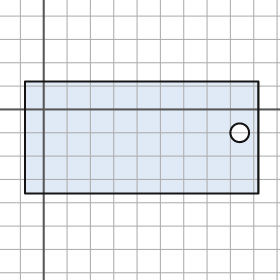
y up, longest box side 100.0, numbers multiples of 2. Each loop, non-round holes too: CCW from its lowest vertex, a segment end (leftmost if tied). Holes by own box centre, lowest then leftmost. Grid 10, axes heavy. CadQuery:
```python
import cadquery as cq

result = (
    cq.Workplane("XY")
    .moveTo(-8.0, -36.0)
    .lineTo(92.0, -36.0)
    .lineTo(92.0, 12.0)
    .lineTo(-8.0, 12.0)
    .close()
    .moveTo(84.0, -10.0)
    .circle(4.0)
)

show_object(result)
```